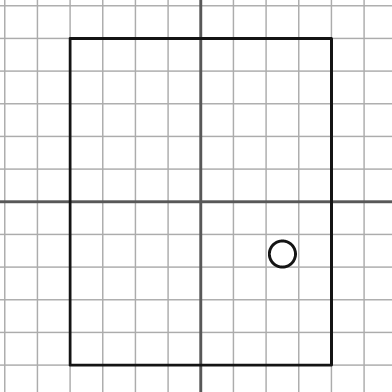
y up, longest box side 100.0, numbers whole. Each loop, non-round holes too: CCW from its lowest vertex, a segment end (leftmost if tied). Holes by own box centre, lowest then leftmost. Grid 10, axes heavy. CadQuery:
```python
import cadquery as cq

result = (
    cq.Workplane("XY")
    .moveTo(-40.0, -50.0)
    .lineTo(40.0, -50.0)
    .lineTo(40.0, 50.0)
    .lineTo(-40.0, 50.0)
    .close()
    .moveTo(25.0, -16.0)
    .circle(4.0)
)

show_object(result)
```